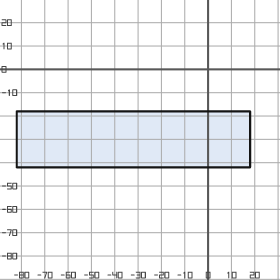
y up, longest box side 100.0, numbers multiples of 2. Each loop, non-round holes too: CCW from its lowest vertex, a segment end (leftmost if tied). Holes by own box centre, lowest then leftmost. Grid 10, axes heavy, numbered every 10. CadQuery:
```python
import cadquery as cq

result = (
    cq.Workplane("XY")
    .moveTo(-82.0, -42.0)
    .lineTo(18.0, -42.0)
    .lineTo(18.0, -18.0)
    .lineTo(-82.0, -18.0)
    .close()
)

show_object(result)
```